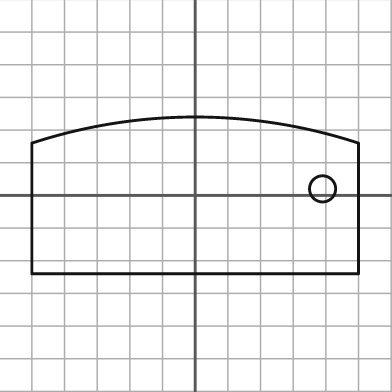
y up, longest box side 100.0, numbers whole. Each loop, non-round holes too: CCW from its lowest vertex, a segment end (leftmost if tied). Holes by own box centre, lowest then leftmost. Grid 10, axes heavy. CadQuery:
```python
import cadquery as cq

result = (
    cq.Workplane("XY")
    .moveTo(-50.0, -24.0)
    .lineTo(50.0, -24.0)
    .lineTo(50.0, 16.0)
    .threePointArc((0.0, 24.0), (-50.0, 16.0))
    .close()
    .moveTo(39.0, 2.0)
    .circle(4.0)
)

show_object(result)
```